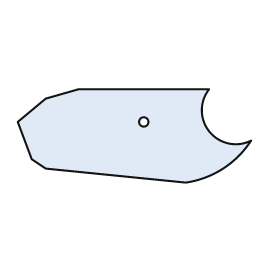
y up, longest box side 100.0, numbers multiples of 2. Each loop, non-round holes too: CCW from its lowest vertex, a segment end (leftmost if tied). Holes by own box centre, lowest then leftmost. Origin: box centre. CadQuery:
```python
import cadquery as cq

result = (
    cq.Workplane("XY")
    .moveTo(22.0, -20.0)
    .threePointArc((38.0, -14.0), (50.0, -2.0))
    .threePointArc((32.0, 2.0), (32.0, 20.0))
    .lineTo(-24.0, 20.0)
    .lineTo(-38.0, 16.0)
    .lineTo(-50.0, 6.0)
    .lineTo(-44.0, -10.0)
    .lineTo(-38.0, -14.0)
    .close()
    .moveTo(4.0, 6.0)
    .circle(2.0)
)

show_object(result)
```